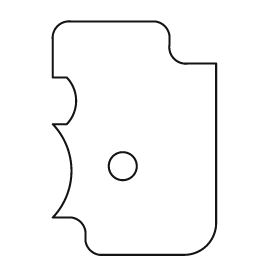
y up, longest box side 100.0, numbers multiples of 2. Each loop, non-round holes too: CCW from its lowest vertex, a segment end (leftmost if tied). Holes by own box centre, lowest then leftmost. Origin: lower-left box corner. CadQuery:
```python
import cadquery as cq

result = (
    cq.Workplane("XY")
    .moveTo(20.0, 0.0)
    .lineTo(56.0, 0.0)
    .threePointArc((66.0, 4.0), (70.0, 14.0))
    .lineTo(70.0, 82.0)
    .lineTo(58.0, 82.0)
    .threePointArc((52.0, 84.0), (50.0, 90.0))
    .lineTo(50.0, 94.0)
    .threePointArc((48.0, 98.0), (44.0, 100.0))
    .lineTo(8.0, 100.0)
    .threePointArc((2.0, 98.0), (0.0, 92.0))
    .lineTo(0.0, 76.0)
    .lineTo(6.0, 76.0)
    .threePointArc((10.0, 66.0), (6.0, 56.0))
    .lineTo(0.0, 56.0)
    .threePointArc((8.0, 36.0), (0.0, 16.0))
    .lineTo(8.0, 16.0)
    .threePointArc((12.0, 14.0), (14.0, 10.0))
    .lineTo(14.0, 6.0)
    .threePointArc((16.0, 2.0), (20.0, 0.0))
    .close()
    .moveTo(30.0, 38.0)
    .circle(6.0)
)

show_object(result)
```